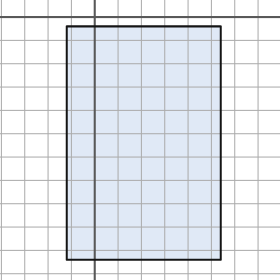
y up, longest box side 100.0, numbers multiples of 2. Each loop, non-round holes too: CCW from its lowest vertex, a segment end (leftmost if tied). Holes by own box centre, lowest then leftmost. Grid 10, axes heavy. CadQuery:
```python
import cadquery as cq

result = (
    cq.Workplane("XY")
    .moveTo(-12.0, -104.0)
    .lineTo(54.0, -104.0)
    .lineTo(54.0, -4.0)
    .lineTo(-12.0, -4.0)
    .close()
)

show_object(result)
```